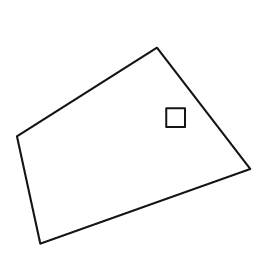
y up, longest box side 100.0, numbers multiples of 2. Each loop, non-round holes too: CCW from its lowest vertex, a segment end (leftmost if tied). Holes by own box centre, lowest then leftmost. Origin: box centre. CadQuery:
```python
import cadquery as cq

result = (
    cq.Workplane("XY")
    .moveTo(-40.0, -42.0)
    .lineTo(50.0, -10.0)
    .lineTo(10.0, 42.0)
    .lineTo(-50.0, 4.0)
    .close()
    .moveTo(14.0, 8.0)
    .lineTo(22.0, 8.0)
    .lineTo(22.0, 16.0)
    .lineTo(14.0, 16.0)
    .close()
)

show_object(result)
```